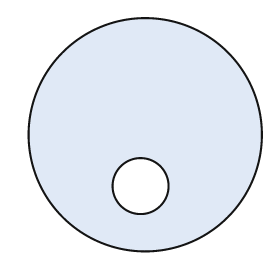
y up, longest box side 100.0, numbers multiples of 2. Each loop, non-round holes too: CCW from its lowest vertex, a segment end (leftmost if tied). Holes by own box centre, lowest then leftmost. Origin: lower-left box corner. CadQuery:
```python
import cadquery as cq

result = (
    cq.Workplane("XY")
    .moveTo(50.0, 50.0)
    .circle(50.0)
    .moveTo(48.0, 28.0)
    .circle(12.0)
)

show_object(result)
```